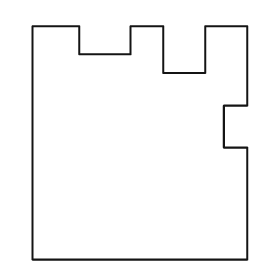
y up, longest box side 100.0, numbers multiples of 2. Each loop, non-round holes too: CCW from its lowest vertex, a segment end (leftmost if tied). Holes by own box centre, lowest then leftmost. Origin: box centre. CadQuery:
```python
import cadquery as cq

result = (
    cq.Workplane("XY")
    .moveTo(-46.0, -50.0)
    .lineTo(46.0, -50.0)
    .lineTo(46.0, -2.0)
    .lineTo(36.0, -2.0)
    .lineTo(36.0, 16.0)
    .lineTo(46.0, 16.0)
    .lineTo(46.0, 50.0)
    .lineTo(28.0, 50.0)
    .lineTo(28.0, 30.0)
    .lineTo(10.0, 30.0)
    .lineTo(10.0, 50.0)
    .lineTo(-4.0, 50.0)
    .lineTo(-4.0, 38.0)
    .lineTo(-26.0, 38.0)
    .lineTo(-26.0, 50.0)
    .lineTo(-46.0, 50.0)
    .close()
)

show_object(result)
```